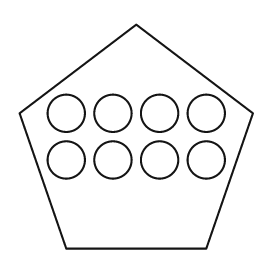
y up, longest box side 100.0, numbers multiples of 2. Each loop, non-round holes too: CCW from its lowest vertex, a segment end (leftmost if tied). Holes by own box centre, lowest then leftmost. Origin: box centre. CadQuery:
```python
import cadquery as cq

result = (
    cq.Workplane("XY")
    .moveTo(-30.0, -48.0)
    .lineTo(30.0, -48.0)
    .lineTo(50.0, 10.0)
    .lineTo(0.0, 48.0)
    .lineTo(-50.0, 10.0)
    .close()
    .moveTo(-30.0, -10.0)
    .circle(8.0)
    .moveTo(-10.0, -10.0)
    .circle(8.0)
    .moveTo(10.0, -10.0)
    .circle(8.0)
    .moveTo(30.0, -10.0)
    .circle(8.0)
    .moveTo(-30.0, 10.0)
    .circle(8.0)
    .moveTo(-10.0, 10.0)
    .circle(8.0)
    .moveTo(10.0, 10.0)
    .circle(8.0)
    .moveTo(30.0, 10.0)
    .circle(8.0)
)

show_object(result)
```